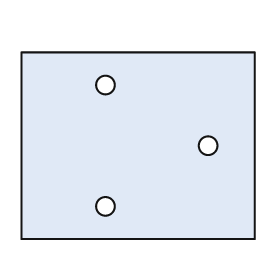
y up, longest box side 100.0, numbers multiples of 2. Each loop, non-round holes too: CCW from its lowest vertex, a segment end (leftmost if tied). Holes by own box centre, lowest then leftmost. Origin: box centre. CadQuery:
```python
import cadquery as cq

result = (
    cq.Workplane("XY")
    .moveTo(-50.0, -40.0)
    .lineTo(50.0, -40.0)
    .lineTo(50.0, 40.0)
    .lineTo(-50.0, 40.0)
    .close()
    .moveTo(-14.0, -26.0)
    .circle(4.0)
    .moveTo(30.0, 0.0)
    .circle(4.0)
    .moveTo(-14.0, 26.0)
    .circle(4.0)
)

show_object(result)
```